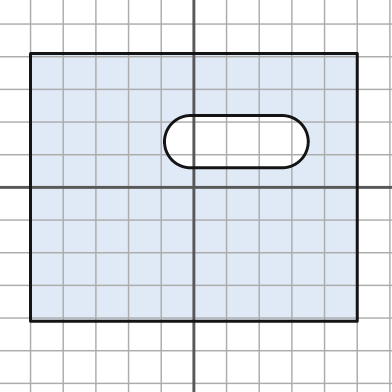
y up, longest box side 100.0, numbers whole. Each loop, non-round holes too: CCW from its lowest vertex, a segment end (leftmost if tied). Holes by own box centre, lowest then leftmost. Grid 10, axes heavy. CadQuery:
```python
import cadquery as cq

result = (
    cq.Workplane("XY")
    .moveTo(-50.0, -41.0)
    .lineTo(50.0, -41.0)
    .lineTo(50.0, 41.0)
    .lineTo(-50.0, 41.0)
    .close()
    .moveTo(-1.0, 6.0)
    .lineTo(27.0, 6.0)
    .threePointArc((35.0, 14.0), (27.0, 22.0))
    .lineTo(-1.0, 22.0)
    .threePointArc((-9.0, 14.0), (-1.0, 6.0))
    .close()
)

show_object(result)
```